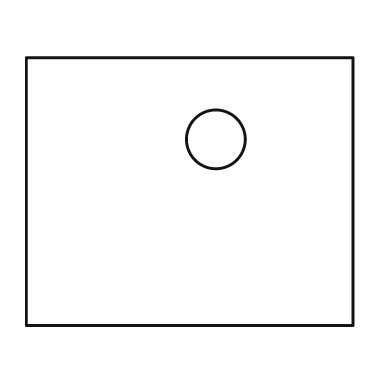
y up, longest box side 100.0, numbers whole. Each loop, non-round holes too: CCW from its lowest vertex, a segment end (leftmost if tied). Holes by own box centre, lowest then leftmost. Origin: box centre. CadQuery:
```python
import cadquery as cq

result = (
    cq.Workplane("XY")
    .moveTo(-50.0, -41.0)
    .lineTo(50.0, -41.0)
    .lineTo(50.0, 41.0)
    .lineTo(-50.0, 41.0)
    .close()
    .moveTo(8.0, 16.0)
    .circle(9.0)
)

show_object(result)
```